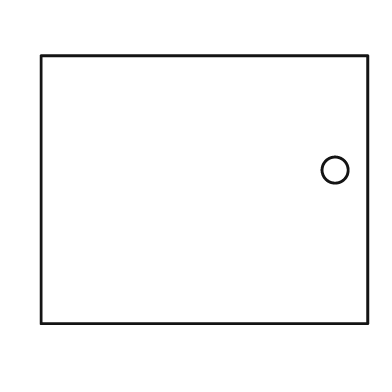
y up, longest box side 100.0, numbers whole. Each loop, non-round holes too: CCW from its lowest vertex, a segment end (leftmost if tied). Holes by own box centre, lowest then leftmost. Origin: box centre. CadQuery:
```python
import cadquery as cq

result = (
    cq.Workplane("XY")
    .moveTo(-50.0, -41.0)
    .lineTo(50.0, -41.0)
    .lineTo(50.0, 41.0)
    .lineTo(-50.0, 41.0)
    .close()
    .moveTo(40.0, 6.0)
    .circle(4.0)
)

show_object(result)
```